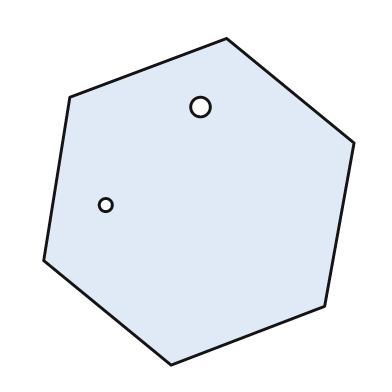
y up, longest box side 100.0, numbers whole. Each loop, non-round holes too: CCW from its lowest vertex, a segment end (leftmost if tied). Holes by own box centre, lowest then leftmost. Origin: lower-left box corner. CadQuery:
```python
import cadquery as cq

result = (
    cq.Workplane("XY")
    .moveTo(39.0, 0.0)
    .lineTo(86.0, 18.0)
    .lineTo(95.0, 68.0)
    .lineTo(56.0, 100.0)
    .lineTo(8.0, 82.0)
    .lineTo(0.0, 32.0)
    .close()
    .moveTo(19.0, 49.0)
    .circle(2.0)
    .moveTo(48.0, 79.0)
    .circle(3.0)
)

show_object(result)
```